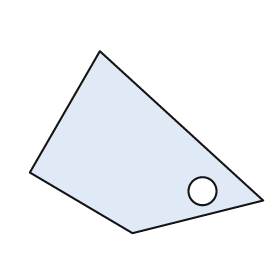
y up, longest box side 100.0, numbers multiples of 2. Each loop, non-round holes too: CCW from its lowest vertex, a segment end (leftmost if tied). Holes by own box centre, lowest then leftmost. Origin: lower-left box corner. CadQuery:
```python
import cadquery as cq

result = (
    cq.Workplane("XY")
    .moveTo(44.0, 0.0)
    .lineTo(100.0, 14.0)
    .lineTo(30.0, 78.0)
    .lineTo(0.0, 26.0)
    .close()
    .moveTo(74.0, 18.0)
    .circle(6.0)
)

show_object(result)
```